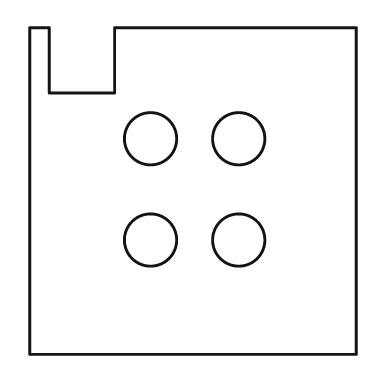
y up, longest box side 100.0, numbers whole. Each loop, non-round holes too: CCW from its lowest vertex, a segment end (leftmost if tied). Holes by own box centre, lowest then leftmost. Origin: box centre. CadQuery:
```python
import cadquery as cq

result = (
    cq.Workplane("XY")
    .moveTo(-50.0, -50.0)
    .lineTo(50.0, -50.0)
    .lineTo(50.0, 50.0)
    .lineTo(-24.0, 50.0)
    .lineTo(-24.0, 30.0)
    .lineTo(-44.0, 30.0)
    .lineTo(-44.0, 50.0)
    .lineTo(-50.0, 50.0)
    .close()
    .moveTo(-13.0, -15.0)
    .circle(8.0)
    .moveTo(14.0, -15.0)
    .circle(8.0)
    .moveTo(-13.0, 16.0)
    .circle(8.0)
    .moveTo(14.0, 16.0)
    .circle(8.0)
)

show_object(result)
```